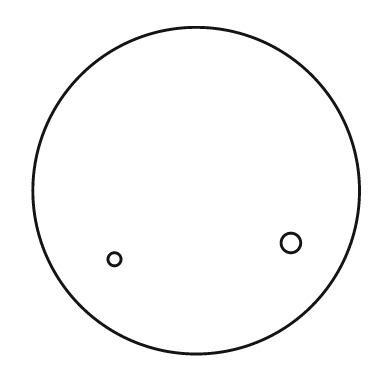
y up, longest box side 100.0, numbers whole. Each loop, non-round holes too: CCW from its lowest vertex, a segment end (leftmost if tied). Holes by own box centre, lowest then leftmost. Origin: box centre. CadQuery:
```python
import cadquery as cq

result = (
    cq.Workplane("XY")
    .moveTo(0.0, 0.0)
    .circle(50.0)
    .moveTo(-25.0, -21.0)
    .circle(2.0)
    .moveTo(29.0, -16.0)
    .circle(3.0)
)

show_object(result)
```